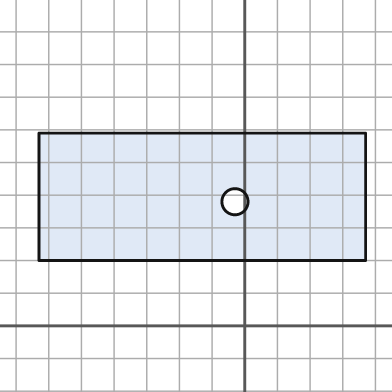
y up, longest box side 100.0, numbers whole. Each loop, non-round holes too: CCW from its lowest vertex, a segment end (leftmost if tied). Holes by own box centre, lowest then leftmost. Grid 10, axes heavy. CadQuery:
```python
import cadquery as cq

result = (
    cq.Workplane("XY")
    .moveTo(-63.0, 20.0)
    .lineTo(37.0, 20.0)
    .lineTo(37.0, 59.0)
    .lineTo(-63.0, 59.0)
    .close()
    .moveTo(-3.0, 38.0)
    .circle(4.0)
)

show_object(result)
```